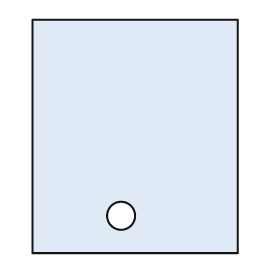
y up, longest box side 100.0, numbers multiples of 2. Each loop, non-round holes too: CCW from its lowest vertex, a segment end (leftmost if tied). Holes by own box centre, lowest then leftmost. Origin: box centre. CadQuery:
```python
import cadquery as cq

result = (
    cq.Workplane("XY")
    .moveTo(-44.0, -50.0)
    .lineTo(44.0, -50.0)
    .lineTo(44.0, 50.0)
    .lineTo(-44.0, 50.0)
    .close()
    .moveTo(-6.0, -34.0)
    .circle(6.0)
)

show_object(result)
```